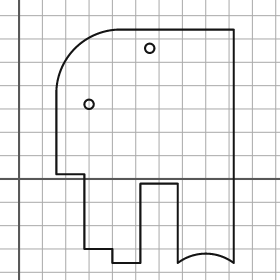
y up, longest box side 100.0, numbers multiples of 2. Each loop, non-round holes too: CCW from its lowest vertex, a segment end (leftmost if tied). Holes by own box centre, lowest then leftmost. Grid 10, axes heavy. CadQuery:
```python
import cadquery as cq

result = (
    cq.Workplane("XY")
    .moveTo(40.0, -36.0)
    .lineTo(52.0, -36.0)
    .lineTo(52.0, -2.0)
    .lineTo(68.0, -2.0)
    .lineTo(68.0, -36.0)
    .threePointArc((80.0, -32.0), (92.0, -36.0))
    .lineTo(92.0, 64.0)
    .lineTo(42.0, 64.0)
    .threePointArc((24.0, 56.0), (16.0, 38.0))
    .lineTo(16.0, 2.0)
    .lineTo(28.0, 2.0)
    .lineTo(28.0, -30.0)
    .lineTo(40.0, -30.0)
    .close()
    .moveTo(30.0, 32.0)
    .circle(2.0)
    .moveTo(56.0, 56.0)
    .circle(2.0)
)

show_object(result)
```